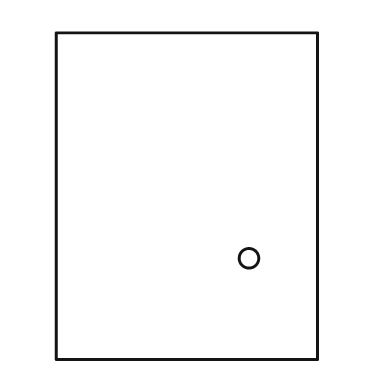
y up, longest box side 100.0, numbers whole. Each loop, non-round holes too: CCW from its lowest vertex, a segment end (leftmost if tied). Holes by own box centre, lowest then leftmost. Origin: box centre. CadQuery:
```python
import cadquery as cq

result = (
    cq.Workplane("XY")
    .moveTo(-40.0, -50.0)
    .lineTo(40.0, -50.0)
    .lineTo(40.0, 50.0)
    .lineTo(-40.0, 50.0)
    .close()
    .moveTo(19.0, -19.0)
    .circle(3.0)
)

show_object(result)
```